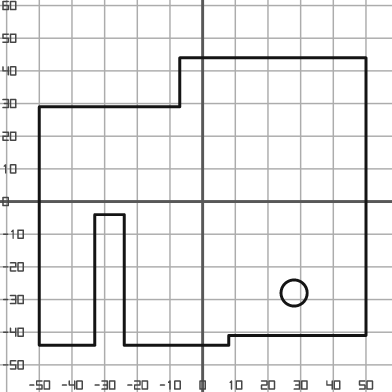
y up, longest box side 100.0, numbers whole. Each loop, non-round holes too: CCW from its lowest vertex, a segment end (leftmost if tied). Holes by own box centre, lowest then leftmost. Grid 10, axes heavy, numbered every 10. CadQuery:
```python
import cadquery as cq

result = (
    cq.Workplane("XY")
    .moveTo(-50.0, -44.0)
    .lineTo(-33.0, -44.0)
    .lineTo(-33.0, -4.0)
    .lineTo(-24.0, -4.0)
    .lineTo(-24.0, -44.0)
    .lineTo(8.0, -44.0)
    .lineTo(8.0, -41.0)
    .lineTo(50.0, -41.0)
    .lineTo(50.0, 44.0)
    .lineTo(-7.0, 44.0)
    .lineTo(-7.0, 29.0)
    .lineTo(-50.0, 29.0)
    .close()
    .moveTo(28.0, -28.0)
    .circle(4.0)
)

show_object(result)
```